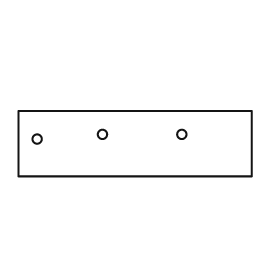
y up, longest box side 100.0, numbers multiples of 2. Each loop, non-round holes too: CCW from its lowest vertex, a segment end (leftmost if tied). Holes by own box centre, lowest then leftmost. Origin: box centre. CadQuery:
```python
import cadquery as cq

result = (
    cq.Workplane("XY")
    .moveTo(-50.0, -14.0)
    .lineTo(50.0, -14.0)
    .lineTo(50.0, 14.0)
    .lineTo(-50.0, 14.0)
    .close()
    .moveTo(-42.0, 2.0)
    .circle(2.0)
    .moveTo(-14.0, 4.0)
    .circle(2.0)
    .moveTo(20.0, 4.0)
    .circle(2.0)
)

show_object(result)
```